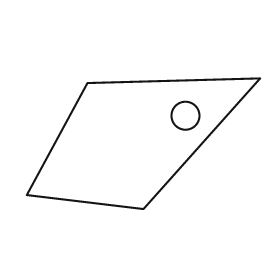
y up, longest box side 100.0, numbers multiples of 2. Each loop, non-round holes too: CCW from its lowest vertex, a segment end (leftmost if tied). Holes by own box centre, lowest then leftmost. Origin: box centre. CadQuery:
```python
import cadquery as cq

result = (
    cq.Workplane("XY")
    .moveTo(0.0, -28.0)
    .lineTo(50.0, 28.0)
    .lineTo(-24.0, 26.0)
    .lineTo(-50.0, -22.0)
    .close()
    .moveTo(18.0, 12.0)
    .circle(6.0)
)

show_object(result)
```